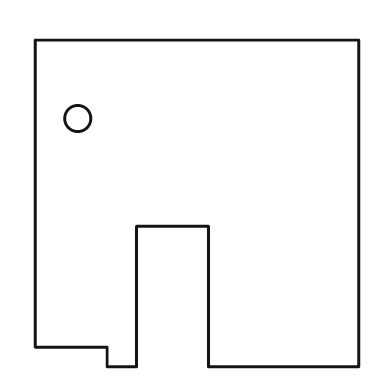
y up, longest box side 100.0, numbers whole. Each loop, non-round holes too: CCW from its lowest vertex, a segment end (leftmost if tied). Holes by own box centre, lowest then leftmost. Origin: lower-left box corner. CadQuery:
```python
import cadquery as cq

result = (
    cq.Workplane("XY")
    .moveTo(22.0, 0.0)
    .lineTo(31.0, 0.0)
    .lineTo(31.0, 43.0)
    .lineTo(53.0, 43.0)
    .lineTo(53.0, 0.0)
    .lineTo(99.0, 0.0)
    .lineTo(99.0, 100.0)
    .lineTo(0.0, 100.0)
    .lineTo(0.0, 6.0)
    .lineTo(22.0, 6.0)
    .close()
    .moveTo(13.0, 76.0)
    .circle(4.0)
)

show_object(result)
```